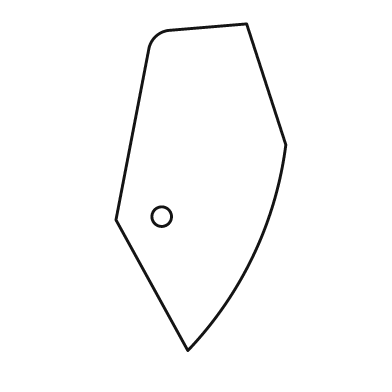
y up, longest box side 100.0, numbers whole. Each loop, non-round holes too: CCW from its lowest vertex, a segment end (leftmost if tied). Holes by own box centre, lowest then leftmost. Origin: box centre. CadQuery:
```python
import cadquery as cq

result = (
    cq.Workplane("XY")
    .moveTo(-4.0, -50.0)
    .threePointArc((16.0, -21.0), (26.0, 13.0))
    .lineTo(14.0, 50.0)
    .lineTo(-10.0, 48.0)
    .threePointArc((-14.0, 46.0), (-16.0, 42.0))
    .lineTo(-26.0, -10.0)
    .close()
    .moveTo(-12.0, -9.0)
    .circle(3.0)
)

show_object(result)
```